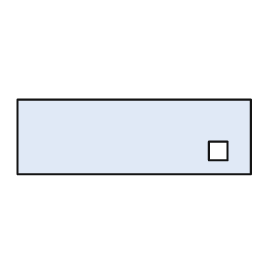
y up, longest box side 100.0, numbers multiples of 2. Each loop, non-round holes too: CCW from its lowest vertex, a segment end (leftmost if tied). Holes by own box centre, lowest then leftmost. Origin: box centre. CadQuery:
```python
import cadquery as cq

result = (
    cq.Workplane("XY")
    .moveTo(-50.0, -16.0)
    .lineTo(50.0, -16.0)
    .lineTo(50.0, 16.0)
    .lineTo(-50.0, 16.0)
    .close()
    .moveTo(32.0, -10.0)
    .lineTo(40.0, -10.0)
    .lineTo(40.0, -2.0)
    .lineTo(32.0, -2.0)
    .close()
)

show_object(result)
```